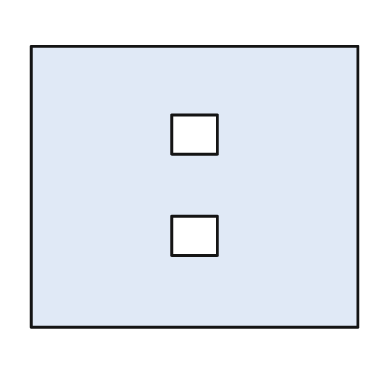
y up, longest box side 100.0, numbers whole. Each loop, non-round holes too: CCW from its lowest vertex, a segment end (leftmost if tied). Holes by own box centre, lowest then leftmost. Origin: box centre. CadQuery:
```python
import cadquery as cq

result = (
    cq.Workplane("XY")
    .moveTo(-50.0, -43.0)
    .lineTo(50.0, -43.0)
    .lineTo(50.0, 43.0)
    .lineTo(-50.0, 43.0)
    .close()
    .moveTo(-7.0, -21.0)
    .lineTo(7.0, -21.0)
    .lineTo(7.0, -9.0)
    .lineTo(-7.0, -9.0)
    .close()
    .moveTo(-7.0, 10.0)
    .lineTo(7.0, 10.0)
    .lineTo(7.0, 22.0)
    .lineTo(-7.0, 22.0)
    .close()
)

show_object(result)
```